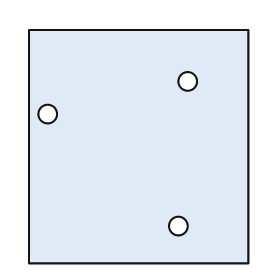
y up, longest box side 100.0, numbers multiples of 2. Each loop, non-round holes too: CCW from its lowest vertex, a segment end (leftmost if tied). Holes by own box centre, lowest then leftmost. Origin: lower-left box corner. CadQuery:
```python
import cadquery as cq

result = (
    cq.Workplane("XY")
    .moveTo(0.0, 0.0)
    .lineTo(94.0, 0.0)
    .lineTo(94.0, 100.0)
    .lineTo(0.0, 100.0)
    .close()
    .moveTo(64.0, 16.0)
    .circle(4.0)
    .moveTo(8.0, 64.0)
    .circle(4.0)
    .moveTo(68.0, 78.0)
    .circle(4.0)
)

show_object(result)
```